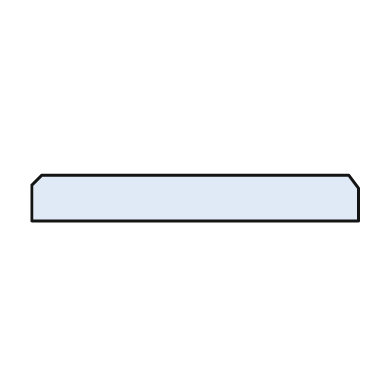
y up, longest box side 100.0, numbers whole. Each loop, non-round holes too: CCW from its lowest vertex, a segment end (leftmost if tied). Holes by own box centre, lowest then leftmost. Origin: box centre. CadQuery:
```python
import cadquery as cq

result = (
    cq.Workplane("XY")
    .moveTo(-50.0, -7.0)
    .lineTo(50.0, -7.0)
    .lineTo(50.0, 3.0)
    .lineTo(47.0, 7.0)
    .lineTo(-47.0, 7.0)
    .lineTo(-50.0, 4.0)
    .close()
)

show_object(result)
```